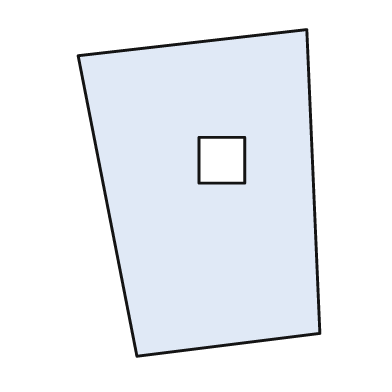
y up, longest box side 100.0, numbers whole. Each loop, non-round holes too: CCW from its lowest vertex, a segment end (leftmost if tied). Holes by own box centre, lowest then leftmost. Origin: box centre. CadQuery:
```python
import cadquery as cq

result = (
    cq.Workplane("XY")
    .moveTo(-19.0, -50.0)
    .lineTo(37.0, -43.0)
    .lineTo(33.0, 50.0)
    .lineTo(-37.0, 42.0)
    .close()
    .moveTo(0.0, 3.0)
    .lineTo(14.0, 3.0)
    .lineTo(14.0, 17.0)
    .lineTo(0.0, 17.0)
    .close()
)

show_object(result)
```